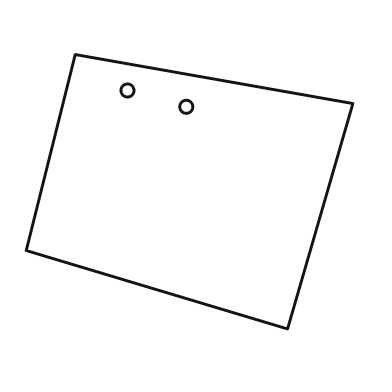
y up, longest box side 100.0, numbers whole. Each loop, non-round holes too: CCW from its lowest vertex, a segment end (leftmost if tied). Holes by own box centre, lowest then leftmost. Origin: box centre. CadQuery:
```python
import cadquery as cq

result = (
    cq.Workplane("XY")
    .moveTo(30.0, -42.0)
    .lineTo(50.0, 27.0)
    .lineTo(-35.0, 42.0)
    .lineTo(-50.0, -18.0)
    .close()
    .moveTo(-1.0, 26.0)
    .circle(2.0)
    .moveTo(-19.0, 31.0)
    .circle(2.0)
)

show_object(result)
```